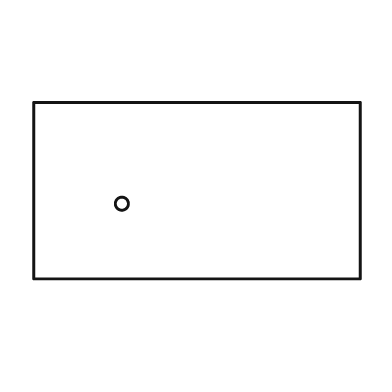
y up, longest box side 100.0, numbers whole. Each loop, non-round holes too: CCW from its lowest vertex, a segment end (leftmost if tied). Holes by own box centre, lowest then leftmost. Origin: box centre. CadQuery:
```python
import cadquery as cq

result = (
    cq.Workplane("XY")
    .moveTo(-50.0, -27.0)
    .lineTo(50.0, -27.0)
    .lineTo(50.0, 27.0)
    .lineTo(-50.0, 27.0)
    .close()
    .moveTo(-23.0, -4.0)
    .circle(2.0)
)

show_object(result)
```